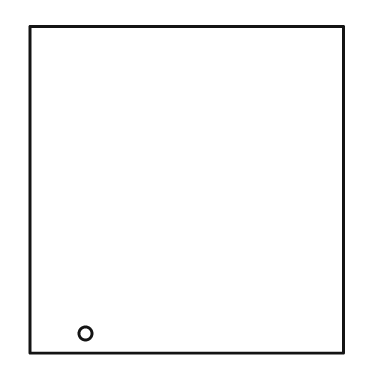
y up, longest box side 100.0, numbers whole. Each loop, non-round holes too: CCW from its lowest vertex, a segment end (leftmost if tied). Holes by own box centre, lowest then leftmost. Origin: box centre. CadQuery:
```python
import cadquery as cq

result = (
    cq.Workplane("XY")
    .moveTo(-48.0, -50.0)
    .lineTo(48.0, -50.0)
    .lineTo(48.0, 50.0)
    .lineTo(-48.0, 50.0)
    .close()
    .moveTo(-31.0, -44.0)
    .circle(2.0)
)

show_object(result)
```